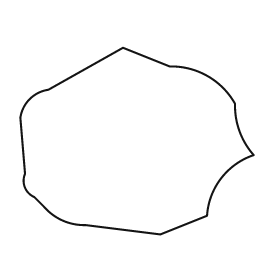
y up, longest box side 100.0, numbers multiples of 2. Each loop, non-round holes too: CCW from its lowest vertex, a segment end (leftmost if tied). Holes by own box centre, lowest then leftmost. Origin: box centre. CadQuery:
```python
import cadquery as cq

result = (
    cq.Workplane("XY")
    .moveTo(10.0, -40.0)
    .lineTo(30.0, -32.0)
    .threePointArc((36.0, -16.0), (50.0, -6.0))
    .threePointArc((44.0, 4.0), (42.0, 16.0))
    .threePointArc((30.0, 28.0), (14.0, 32.0))
    .lineTo(-6.0, 40.0)
    .lineTo(-38.0, 22.0)
    .threePointArc((-46.0, 18.0), (-50.0, 10.0))
    .lineTo(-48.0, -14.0)
    .threePointArc((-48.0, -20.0), (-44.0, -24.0))
    .lineTo(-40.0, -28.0)
    .threePointArc((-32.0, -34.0), (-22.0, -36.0))
    .close()
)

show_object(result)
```